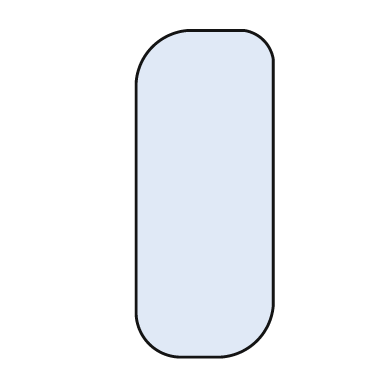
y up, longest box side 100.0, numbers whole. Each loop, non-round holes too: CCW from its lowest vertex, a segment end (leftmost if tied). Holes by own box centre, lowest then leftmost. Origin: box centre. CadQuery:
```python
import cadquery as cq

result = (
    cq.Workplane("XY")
    .moveTo(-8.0, -50.0)
    .lineTo(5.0, -50.0)
    .threePointArc((16.0, -45.0), (21.0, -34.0))
    .lineTo(21.0, 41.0)
    .threePointArc((18.0, 47.0), (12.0, 50.0))
    .lineTo(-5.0, 50.0)
    .threePointArc((-16.0, 45.0), (-21.0, 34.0))
    .lineTo(-21.0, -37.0)
    .threePointArc((-17.0, -46.0), (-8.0, -50.0))
    .close()
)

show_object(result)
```